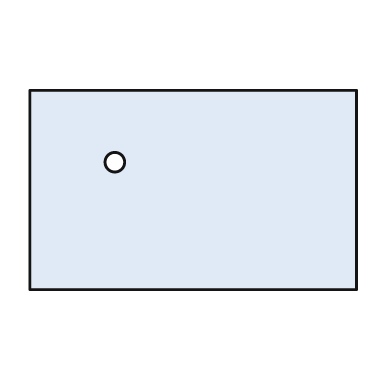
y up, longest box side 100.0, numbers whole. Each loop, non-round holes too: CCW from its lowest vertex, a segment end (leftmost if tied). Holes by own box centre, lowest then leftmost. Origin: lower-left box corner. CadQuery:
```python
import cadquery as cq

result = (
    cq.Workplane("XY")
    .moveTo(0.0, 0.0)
    .lineTo(100.0, 0.0)
    .lineTo(100.0, 61.0)
    .lineTo(0.0, 61.0)
    .close()
    .moveTo(26.0, 39.0)
    .circle(3.0)
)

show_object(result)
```